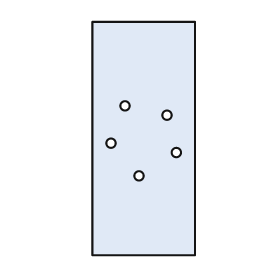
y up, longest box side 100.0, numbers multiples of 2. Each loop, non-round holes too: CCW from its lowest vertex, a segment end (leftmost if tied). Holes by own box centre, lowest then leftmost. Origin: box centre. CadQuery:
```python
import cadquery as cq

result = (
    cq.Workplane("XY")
    .moveTo(-22.0, -50.0)
    .lineTo(22.0, -50.0)
    .lineTo(22.0, 50.0)
    .lineTo(-22.0, 50.0)
    .close()
    .moveTo(-2.0, -16.0)
    .circle(2.0)
    .moveTo(14.0, -6.0)
    .circle(2.0)
    .moveTo(-14.0, -2.0)
    .circle(2.0)
    .moveTo(10.0, 10.0)
    .circle(2.0)
    .moveTo(-8.0, 14.0)
    .circle(2.0)
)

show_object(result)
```